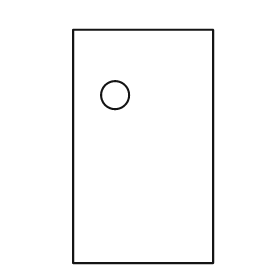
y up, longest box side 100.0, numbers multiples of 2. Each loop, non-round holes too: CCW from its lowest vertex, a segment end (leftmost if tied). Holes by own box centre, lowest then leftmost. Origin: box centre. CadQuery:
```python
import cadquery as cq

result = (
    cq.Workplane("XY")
    .moveTo(-30.0, -50.0)
    .lineTo(30.0, -50.0)
    .lineTo(30.0, 50.0)
    .lineTo(-30.0, 50.0)
    .close()
    .moveTo(-12.0, 22.0)
    .circle(6.0)
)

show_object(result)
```